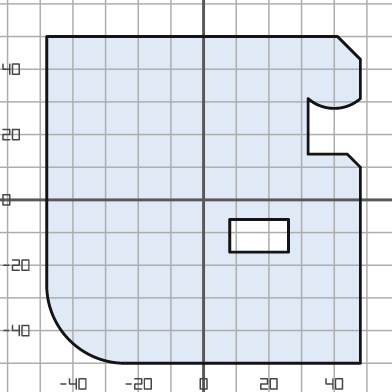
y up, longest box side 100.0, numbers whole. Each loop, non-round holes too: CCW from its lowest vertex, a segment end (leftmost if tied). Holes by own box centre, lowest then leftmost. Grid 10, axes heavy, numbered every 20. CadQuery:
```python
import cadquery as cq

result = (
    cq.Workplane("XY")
    .moveTo(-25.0, -50.0)
    .lineTo(48.0, -50.0)
    .lineTo(48.0, 10.0)
    .lineTo(44.0, 14.0)
    .lineTo(32.0, 14.0)
    .lineTo(32.0, 31.0)
    .threePointArc((40.0, 28.0), (48.0, 31.0))
    .lineTo(48.0, 43.0)
    .lineTo(41.0, 50.0)
    .lineTo(-48.0, 50.0)
    .lineTo(-48.0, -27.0)
    .threePointArc((-41.0, -43.0), (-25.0, -50.0))
    .close()
    .moveTo(8.0, -16.0)
    .lineTo(26.0, -16.0)
    .lineTo(26.0, -6.0)
    .lineTo(8.0, -6.0)
    .close()
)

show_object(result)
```